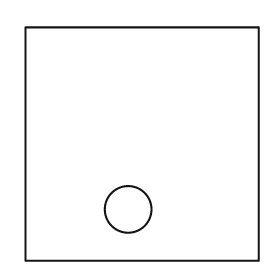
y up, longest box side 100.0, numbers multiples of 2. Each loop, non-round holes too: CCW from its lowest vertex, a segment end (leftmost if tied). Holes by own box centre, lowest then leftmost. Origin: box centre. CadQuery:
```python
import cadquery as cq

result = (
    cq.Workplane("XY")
    .moveTo(-50.0, -50.0)
    .lineTo(50.0, -50.0)
    .lineTo(50.0, 50.0)
    .lineTo(-50.0, 50.0)
    .close()
    .moveTo(-6.0, -28.0)
    .circle(10.0)
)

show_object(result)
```